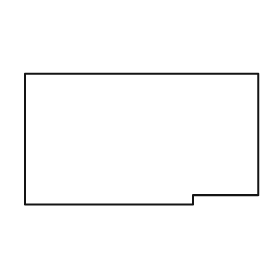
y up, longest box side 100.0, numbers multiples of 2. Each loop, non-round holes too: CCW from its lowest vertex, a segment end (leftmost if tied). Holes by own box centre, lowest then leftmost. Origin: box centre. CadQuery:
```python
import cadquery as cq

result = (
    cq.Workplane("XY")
    .moveTo(-50.0, -28.0)
    .lineTo(22.0, -28.0)
    .lineTo(22.0, -24.0)
    .lineTo(50.0, -24.0)
    .lineTo(50.0, 28.0)
    .lineTo(-50.0, 28.0)
    .close()
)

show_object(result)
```